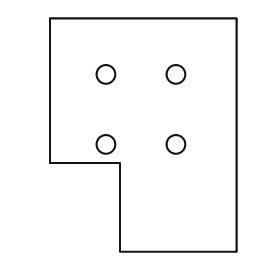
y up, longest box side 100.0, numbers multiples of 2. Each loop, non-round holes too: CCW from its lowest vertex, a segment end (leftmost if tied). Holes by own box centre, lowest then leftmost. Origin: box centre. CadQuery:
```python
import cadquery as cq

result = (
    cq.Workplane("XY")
    .moveTo(-10.0, -50.0)
    .lineTo(40.0, -50.0)
    .lineTo(40.0, 50.0)
    .lineTo(-40.0, 50.0)
    .lineTo(-40.0, -12.0)
    .lineTo(-10.0, -12.0)
    .close()
    .moveTo(-16.0, -4.0)
    .circle(4.0)
    .moveTo(14.0, -4.0)
    .circle(4.0)
    .moveTo(-16.0, 26.0)
    .circle(4.0)
    .moveTo(14.0, 26.0)
    .circle(4.0)
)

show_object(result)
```